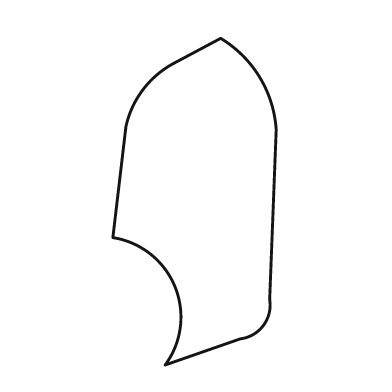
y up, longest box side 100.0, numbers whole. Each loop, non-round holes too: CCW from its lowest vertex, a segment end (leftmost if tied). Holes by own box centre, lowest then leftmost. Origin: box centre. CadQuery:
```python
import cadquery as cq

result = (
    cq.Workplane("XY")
    .moveTo(-9.0, -50.0)
    .lineTo(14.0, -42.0)
    .threePointArc((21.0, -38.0), (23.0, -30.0))
    .lineTo(25.0, 22.0)
    .threePointArc((20.0, 38.0), (8.0, 50.0))
    .lineTo(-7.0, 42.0)
    .threePointArc((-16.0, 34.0), (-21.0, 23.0))
    .lineTo(-25.0, -11.0)
    .threePointArc((-6.0, -26.0), (-9.0, -50.0))
    .close()
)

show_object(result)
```